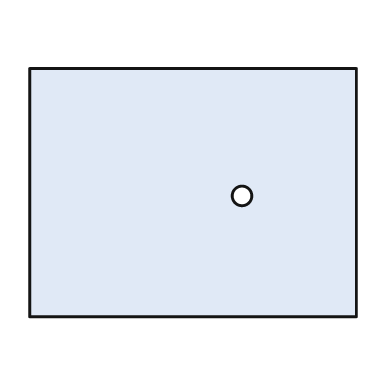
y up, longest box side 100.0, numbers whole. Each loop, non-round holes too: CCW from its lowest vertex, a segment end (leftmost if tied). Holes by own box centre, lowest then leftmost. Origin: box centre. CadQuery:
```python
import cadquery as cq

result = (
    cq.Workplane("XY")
    .moveTo(-50.0, -38.0)
    .lineTo(50.0, -38.0)
    .lineTo(50.0, 38.0)
    .lineTo(-50.0, 38.0)
    .close()
    .moveTo(15.0, -1.0)
    .circle(3.0)
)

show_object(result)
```